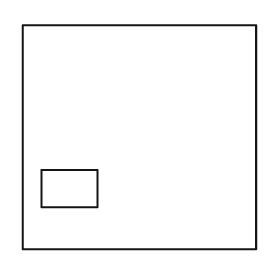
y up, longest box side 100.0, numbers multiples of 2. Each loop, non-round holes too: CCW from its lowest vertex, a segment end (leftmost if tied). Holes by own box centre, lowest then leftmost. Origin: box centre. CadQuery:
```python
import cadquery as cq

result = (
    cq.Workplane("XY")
    .moveTo(-50.0, -48.0)
    .lineTo(50.0, -48.0)
    .lineTo(50.0, 48.0)
    .lineTo(-50.0, 48.0)
    .close()
    .moveTo(-42.0, -30.0)
    .lineTo(-18.0, -30.0)
    .lineTo(-18.0, -14.0)
    .lineTo(-42.0, -14.0)
    .close()
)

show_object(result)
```